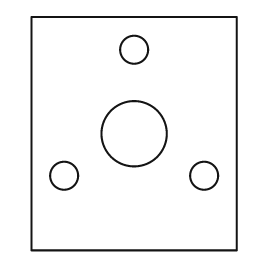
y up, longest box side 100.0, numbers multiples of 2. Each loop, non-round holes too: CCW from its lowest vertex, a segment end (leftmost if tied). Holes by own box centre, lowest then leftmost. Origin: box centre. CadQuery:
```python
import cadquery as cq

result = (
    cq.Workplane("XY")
    .moveTo(-44.0, -50.0)
    .lineTo(44.0, -50.0)
    .lineTo(44.0, 50.0)
    .lineTo(-44.0, 50.0)
    .close()
    .moveTo(-30.0, -18.0)
    .circle(6.0)
    .moveTo(30.0, -18.0)
    .circle(6.0)
    .moveTo(0.0, 0.0)
    .circle(14.0)
    .moveTo(0.0, 36.0)
    .circle(6.0)
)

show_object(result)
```